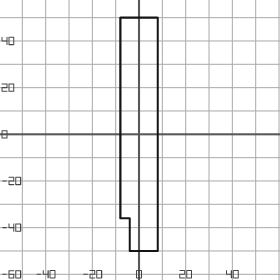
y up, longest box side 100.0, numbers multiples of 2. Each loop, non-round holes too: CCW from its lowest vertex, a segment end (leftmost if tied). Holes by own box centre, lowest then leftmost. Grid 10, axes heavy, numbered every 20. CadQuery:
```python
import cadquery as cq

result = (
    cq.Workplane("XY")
    .moveTo(-4.0, -50.0)
    .lineTo(8.0, -50.0)
    .lineTo(8.0, 50.0)
    .lineTo(-8.0, 50.0)
    .lineTo(-8.0, -36.0)
    .lineTo(-4.0, -36.0)
    .close()
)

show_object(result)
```